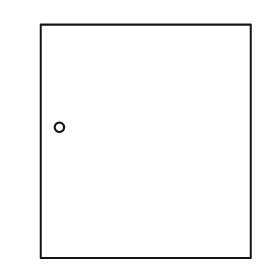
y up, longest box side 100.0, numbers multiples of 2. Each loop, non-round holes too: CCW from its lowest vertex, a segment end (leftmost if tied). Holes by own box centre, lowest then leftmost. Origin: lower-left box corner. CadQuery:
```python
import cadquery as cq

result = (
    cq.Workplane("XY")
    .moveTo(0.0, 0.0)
    .lineTo(90.0, 0.0)
    .lineTo(90.0, 100.0)
    .lineTo(0.0, 100.0)
    .close()
    .moveTo(8.0, 56.0)
    .circle(2.0)
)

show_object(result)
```